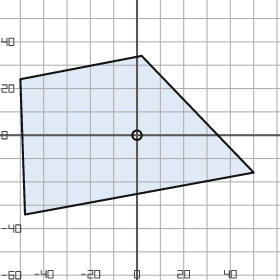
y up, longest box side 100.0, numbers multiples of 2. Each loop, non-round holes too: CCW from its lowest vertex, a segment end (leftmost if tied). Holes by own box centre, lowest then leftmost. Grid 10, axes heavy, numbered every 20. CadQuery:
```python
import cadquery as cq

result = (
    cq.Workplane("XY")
    .moveTo(-48.0, -34.0)
    .lineTo(50.0, -16.0)
    .lineTo(2.0, 34.0)
    .lineTo(-50.0, 24.0)
    .close()
    .moveTo(0.0, 0.0)
    .circle(2.0)
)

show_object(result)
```